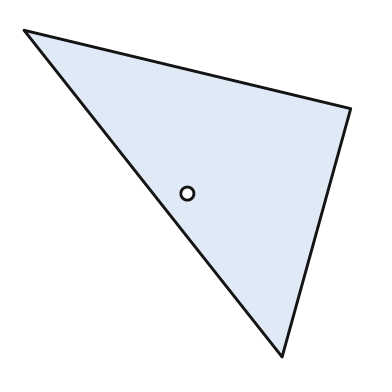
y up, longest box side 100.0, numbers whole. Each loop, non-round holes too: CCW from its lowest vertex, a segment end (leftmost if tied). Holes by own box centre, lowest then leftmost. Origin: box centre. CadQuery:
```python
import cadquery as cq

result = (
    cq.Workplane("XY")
    .moveTo(29.0, -50.0)
    .lineTo(50.0, 26.0)
    .lineTo(-50.0, 50.0)
    .close()
    .moveTo(0.0, 0.0)
    .circle(2.0)
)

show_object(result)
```